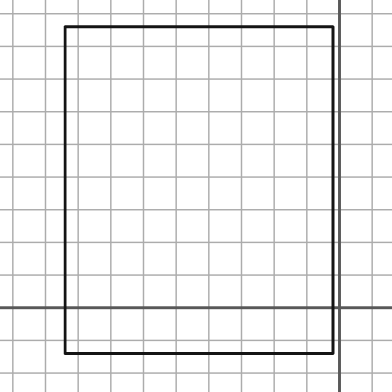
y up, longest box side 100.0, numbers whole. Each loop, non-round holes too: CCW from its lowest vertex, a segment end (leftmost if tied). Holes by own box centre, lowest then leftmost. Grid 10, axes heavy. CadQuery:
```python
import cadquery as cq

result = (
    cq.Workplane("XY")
    .moveTo(-84.0, -14.0)
    .lineTo(-2.0, -14.0)
    .lineTo(-2.0, 86.0)
    .lineTo(-84.0, 86.0)
    .close()
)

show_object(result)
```